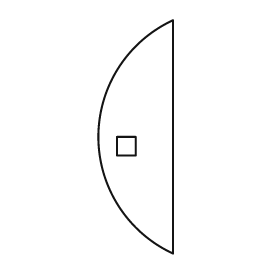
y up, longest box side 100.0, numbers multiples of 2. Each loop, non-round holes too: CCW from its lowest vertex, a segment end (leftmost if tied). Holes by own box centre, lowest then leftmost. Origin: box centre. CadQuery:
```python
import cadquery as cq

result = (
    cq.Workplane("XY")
    .moveTo(16.0, -50.0)
    .lineTo(16.0, 50.0)
    .threePointArc((-16.0, 0.0), (16.0, -50.0))
    .close()
    .moveTo(-8.0, -8.0)
    .lineTo(0.0, -8.0)
    .lineTo(0.0, 0.0)
    .lineTo(-8.0, 0.0)
    .close()
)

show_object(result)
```